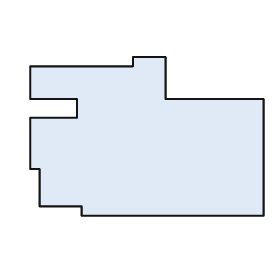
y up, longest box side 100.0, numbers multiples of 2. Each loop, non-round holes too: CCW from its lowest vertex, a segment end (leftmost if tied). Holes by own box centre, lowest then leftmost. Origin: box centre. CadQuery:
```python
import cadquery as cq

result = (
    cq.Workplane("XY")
    .moveTo(-28.0, -34.0)
    .lineTo(50.0, -34.0)
    .lineTo(50.0, 16.0)
    .lineTo(8.0, 16.0)
    .lineTo(8.0, 34.0)
    .lineTo(-6.0, 34.0)
    .lineTo(-6.0, 30.0)
    .lineTo(-50.0, 30.0)
    .lineTo(-50.0, 16.0)
    .lineTo(-30.0, 16.0)
    .lineTo(-30.0, 8.0)
    .lineTo(-50.0, 8.0)
    .lineTo(-50.0, -14.0)
    .lineTo(-46.0, -14.0)
    .lineTo(-46.0, -30.0)
    .lineTo(-28.0, -30.0)
    .close()
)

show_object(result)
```